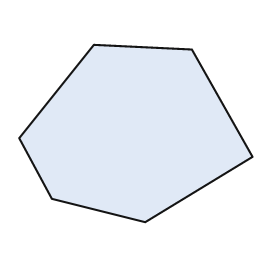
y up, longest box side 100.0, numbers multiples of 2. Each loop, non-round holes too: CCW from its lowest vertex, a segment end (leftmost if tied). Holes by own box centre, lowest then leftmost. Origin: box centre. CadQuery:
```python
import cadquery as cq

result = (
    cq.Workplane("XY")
    .moveTo(4.0, -38.0)
    .lineTo(50.0, -10.0)
    .lineTo(24.0, 36.0)
    .lineTo(-18.0, 38.0)
    .lineTo(-50.0, -2.0)
    .lineTo(-36.0, -28.0)
    .close()
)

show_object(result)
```